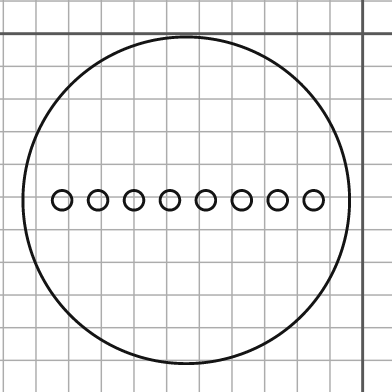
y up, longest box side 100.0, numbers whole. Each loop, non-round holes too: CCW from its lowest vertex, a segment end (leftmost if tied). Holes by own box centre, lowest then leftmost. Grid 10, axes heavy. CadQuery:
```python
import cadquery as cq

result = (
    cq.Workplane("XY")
    .moveTo(-54.0, -51.0)
    .circle(50.0)
    .moveTo(-92.0, -51.0)
    .circle(3.0)
    .moveTo(-81.0, -51.0)
    .circle(3.0)
    .moveTo(-70.0, -51.0)
    .circle(3.0)
    .moveTo(-59.0, -51.0)
    .circle(3.0)
    .moveTo(-48.0, -51.0)
    .circle(3.0)
    .moveTo(-37.0, -51.0)
    .circle(3.0)
    .moveTo(-26.0, -51.0)
    .circle(3.0)
    .moveTo(-15.0, -51.0)
    .circle(3.0)
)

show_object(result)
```